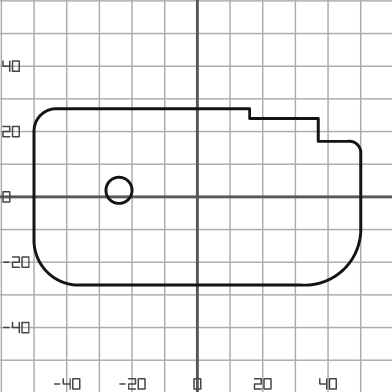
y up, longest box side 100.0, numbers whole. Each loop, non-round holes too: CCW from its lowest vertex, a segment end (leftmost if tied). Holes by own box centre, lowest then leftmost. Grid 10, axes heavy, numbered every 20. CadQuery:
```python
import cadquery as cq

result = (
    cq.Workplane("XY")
    .moveTo(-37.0, -27.0)
    .lineTo(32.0, -27.0)
    .threePointArc((45.0, -22.0), (50.0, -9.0))
    .lineTo(50.0, 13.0)
    .threePointArc((49.0, 16.0), (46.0, 17.0))
    .lineTo(37.0, 17.0)
    .lineTo(37.0, 24.0)
    .lineTo(16.0, 24.0)
    .lineTo(16.0, 27.0)
    .lineTo(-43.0, 27.0)
    .threePointArc((-48.0, 25.0), (-50.0, 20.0))
    .lineTo(-50.0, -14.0)
    .threePointArc((-46.0, -23.0), (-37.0, -27.0))
    .close()
    .moveTo(-24.0, 2.0)
    .circle(4.0)
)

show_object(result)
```